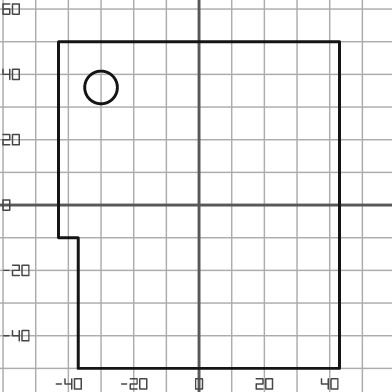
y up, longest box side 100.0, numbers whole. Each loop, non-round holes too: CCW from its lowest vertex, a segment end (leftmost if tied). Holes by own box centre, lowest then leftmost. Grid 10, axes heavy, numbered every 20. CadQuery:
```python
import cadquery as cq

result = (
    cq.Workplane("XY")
    .moveTo(-37.0, -50.0)
    .lineTo(43.0, -50.0)
    .lineTo(43.0, 50.0)
    .lineTo(-43.0, 50.0)
    .lineTo(-43.0, -10.0)
    .lineTo(-37.0, -10.0)
    .close()
    .moveTo(-30.0, 36.0)
    .circle(5.0)
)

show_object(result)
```